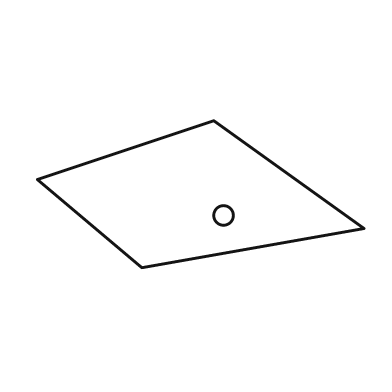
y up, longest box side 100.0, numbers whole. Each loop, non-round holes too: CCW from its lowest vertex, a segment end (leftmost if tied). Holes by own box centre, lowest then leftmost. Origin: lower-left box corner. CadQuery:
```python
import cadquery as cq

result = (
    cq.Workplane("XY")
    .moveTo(32.0, 0.0)
    .lineTo(100.0, 12.0)
    .lineTo(54.0, 45.0)
    .lineTo(0.0, 27.0)
    .close()
    .moveTo(57.0, 16.0)
    .circle(3.0)
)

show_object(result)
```